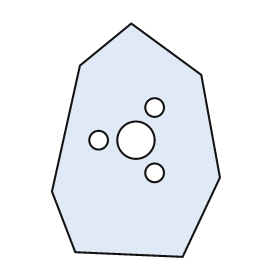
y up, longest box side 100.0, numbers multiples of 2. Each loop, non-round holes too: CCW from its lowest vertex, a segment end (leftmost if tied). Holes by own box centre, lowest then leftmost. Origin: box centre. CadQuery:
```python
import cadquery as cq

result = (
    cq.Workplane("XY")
    .moveTo(20.0, -50.0)
    .lineTo(36.0, -16.0)
    .lineTo(28.0, 28.0)
    .lineTo(-2.0, 50.0)
    .lineTo(-24.0, 32.0)
    .lineTo(-36.0, -22.0)
    .lineTo(-26.0, -48.0)
    .close()
    .moveTo(8.0, -14.0)
    .circle(4.0)
    .moveTo(-16.0, 0.0)
    .circle(4.0)
    .moveTo(0.0, 0.0)
    .circle(8.0)
    .moveTo(8.0, 14.0)
    .circle(4.0)
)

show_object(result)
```